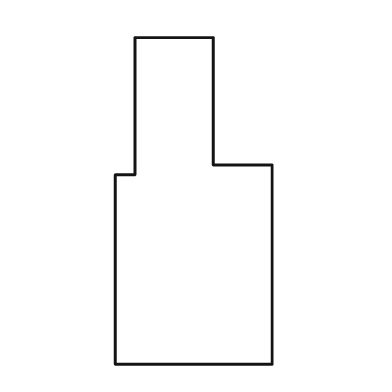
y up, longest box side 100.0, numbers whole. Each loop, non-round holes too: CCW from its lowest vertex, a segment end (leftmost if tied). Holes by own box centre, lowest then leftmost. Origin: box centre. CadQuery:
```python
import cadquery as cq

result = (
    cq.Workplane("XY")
    .moveTo(-24.0, -50.0)
    .lineTo(24.0, -50.0)
    .lineTo(24.0, 11.0)
    .lineTo(6.0, 11.0)
    .lineTo(6.0, 50.0)
    .lineTo(-18.0, 50.0)
    .lineTo(-18.0, 8.0)
    .lineTo(-24.0, 8.0)
    .close()
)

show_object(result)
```